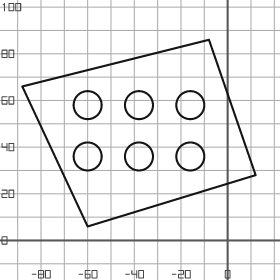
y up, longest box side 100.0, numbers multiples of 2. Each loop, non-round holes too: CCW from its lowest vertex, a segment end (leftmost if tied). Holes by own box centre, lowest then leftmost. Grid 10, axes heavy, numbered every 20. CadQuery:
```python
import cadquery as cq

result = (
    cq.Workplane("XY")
    .moveTo(-60.0, 6.0)
    .lineTo(12.0, 28.0)
    .lineTo(-8.0, 86.0)
    .lineTo(-88.0, 66.0)
    .close()
    .moveTo(-60.0, 36.0)
    .circle(6.0)
    .moveTo(-38.0, 36.0)
    .circle(6.0)
    .moveTo(-16.0, 36.0)
    .circle(6.0)
    .moveTo(-60.0, 58.0)
    .circle(6.0)
    .moveTo(-38.0, 58.0)
    .circle(6.0)
    .moveTo(-16.0, 58.0)
    .circle(6.0)
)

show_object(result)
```